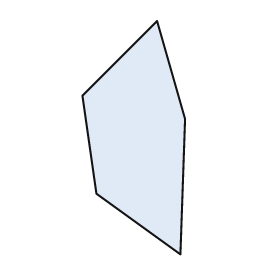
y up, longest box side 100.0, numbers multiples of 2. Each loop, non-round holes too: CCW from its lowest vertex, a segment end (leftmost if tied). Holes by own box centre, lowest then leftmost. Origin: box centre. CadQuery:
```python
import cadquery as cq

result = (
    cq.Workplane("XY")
    .moveTo(20.0, -50.0)
    .lineTo(22.0, 8.0)
    .lineTo(10.0, 50.0)
    .lineTo(-22.0, 18.0)
    .lineTo(-16.0, -24.0)
    .close()
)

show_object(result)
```